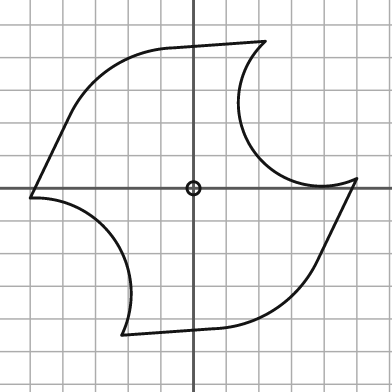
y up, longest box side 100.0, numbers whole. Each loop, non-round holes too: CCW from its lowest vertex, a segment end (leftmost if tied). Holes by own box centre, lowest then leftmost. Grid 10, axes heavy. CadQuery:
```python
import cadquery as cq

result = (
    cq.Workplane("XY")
    .moveTo(-22.0, -45.0)
    .lineTo(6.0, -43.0)
    .threePointArc((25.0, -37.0), (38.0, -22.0))
    .lineTo(50.0, 3.0)
    .threePointArc((18.0, 12.0), (22.0, 45.0))
    .lineTo(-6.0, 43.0)
    .threePointArc((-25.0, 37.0), (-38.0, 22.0))
    .lineTo(-50.0, -3.0)
    .threePointArc((-24.0, -16.0), (-22.0, -45.0))
    .close()
    .moveTo(0.0, 0.0)
    .circle(2.0)
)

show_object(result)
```